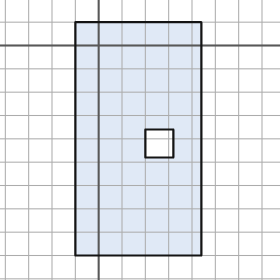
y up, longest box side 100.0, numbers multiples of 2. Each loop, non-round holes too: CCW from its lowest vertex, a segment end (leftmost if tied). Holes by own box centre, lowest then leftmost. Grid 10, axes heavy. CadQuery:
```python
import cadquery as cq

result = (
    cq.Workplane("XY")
    .moveTo(-10.0, -90.0)
    .lineTo(44.0, -90.0)
    .lineTo(44.0, 10.0)
    .lineTo(-10.0, 10.0)
    .close()
    .moveTo(20.0, -48.0)
    .lineTo(32.0, -48.0)
    .lineTo(32.0, -36.0)
    .lineTo(20.0, -36.0)
    .close()
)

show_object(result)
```